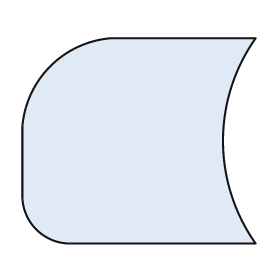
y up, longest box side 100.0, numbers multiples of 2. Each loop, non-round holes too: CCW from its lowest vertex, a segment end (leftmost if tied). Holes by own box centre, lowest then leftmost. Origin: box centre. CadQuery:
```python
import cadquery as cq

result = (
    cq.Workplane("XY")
    .moveTo(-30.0, -44.0)
    .lineTo(50.0, -44.0)
    .threePointArc((36.0, 0.0), (50.0, 44.0))
    .lineTo(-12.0, 44.0)
    .threePointArc((-38.0, 32.0), (-50.0, 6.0))
    .lineTo(-50.0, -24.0)
    .threePointArc((-44.0, -38.0), (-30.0, -44.0))
    .close()
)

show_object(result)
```